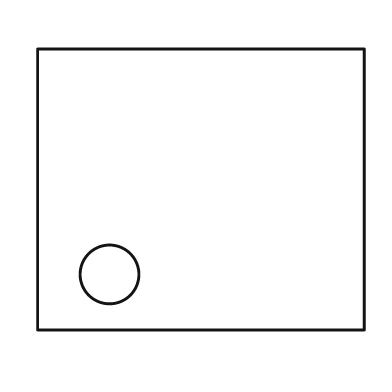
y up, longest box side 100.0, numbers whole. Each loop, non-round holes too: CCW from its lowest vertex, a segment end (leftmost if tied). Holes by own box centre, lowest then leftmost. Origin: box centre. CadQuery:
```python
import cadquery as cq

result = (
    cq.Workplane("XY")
    .moveTo(-50.0, -43.0)
    .lineTo(50.0, -43.0)
    .lineTo(50.0, 43.0)
    .lineTo(-50.0, 43.0)
    .close()
    .moveTo(-28.0, -26.0)
    .circle(9.0)
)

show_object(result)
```